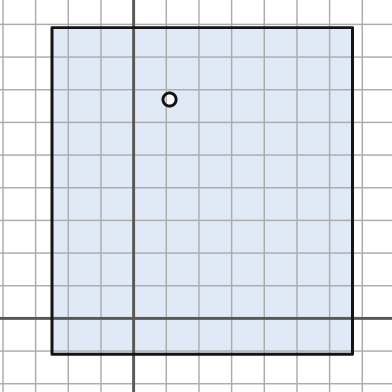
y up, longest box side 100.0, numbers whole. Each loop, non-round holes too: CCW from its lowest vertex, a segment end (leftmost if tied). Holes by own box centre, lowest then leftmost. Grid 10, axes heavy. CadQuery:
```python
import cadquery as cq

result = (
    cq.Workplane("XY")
    .moveTo(-25.0, -11.0)
    .lineTo(67.0, -11.0)
    .lineTo(67.0, 89.0)
    .lineTo(-25.0, 89.0)
    .close()
    .moveTo(11.0, 67.0)
    .circle(2.0)
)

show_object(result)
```